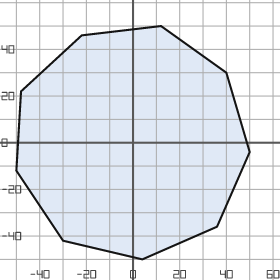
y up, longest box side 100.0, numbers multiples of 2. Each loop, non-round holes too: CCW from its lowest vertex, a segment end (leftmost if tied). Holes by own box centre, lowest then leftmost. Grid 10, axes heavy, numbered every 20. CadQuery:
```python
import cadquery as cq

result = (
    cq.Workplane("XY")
    .moveTo(4.0, -50.0)
    .lineTo(36.0, -36.0)
    .lineTo(50.0, -4.0)
    .lineTo(40.0, 30.0)
    .lineTo(12.0, 50.0)
    .lineTo(-22.0, 46.0)
    .lineTo(-48.0, 22.0)
    .lineTo(-50.0, -12.0)
    .lineTo(-30.0, -42.0)
    .close()
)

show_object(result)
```